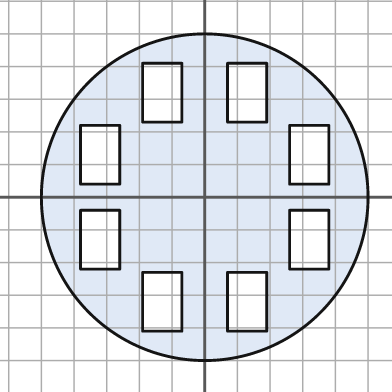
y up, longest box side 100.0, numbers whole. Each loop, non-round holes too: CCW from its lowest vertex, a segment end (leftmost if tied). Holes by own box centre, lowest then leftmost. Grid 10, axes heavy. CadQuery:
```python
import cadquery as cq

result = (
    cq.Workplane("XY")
    .moveTo(0.0, 0.0)
    .circle(50.0)
    .moveTo(-19.0, -41.0)
    .lineTo(-7.0, -41.0)
    .lineTo(-7.0, -23.0)
    .lineTo(-19.0, -23.0)
    .close()
    .moveTo(7.0, -41.0)
    .lineTo(19.0, -41.0)
    .lineTo(19.0, -23.0)
    .lineTo(7.0, -23.0)
    .close()
    .moveTo(-38.0, -22.0)
    .lineTo(-26.0, -22.0)
    .lineTo(-26.0, -4.0)
    .lineTo(-38.0, -4.0)
    .close()
    .moveTo(26.0, -22.0)
    .lineTo(38.0, -22.0)
    .lineTo(38.0, -4.0)
    .lineTo(26.0, -4.0)
    .close()
    .moveTo(-38.0, 4.0)
    .lineTo(-26.0, 4.0)
    .lineTo(-26.0, 22.0)
    .lineTo(-38.0, 22.0)
    .close()
    .moveTo(26.0, 4.0)
    .lineTo(38.0, 4.0)
    .lineTo(38.0, 22.0)
    .lineTo(26.0, 22.0)
    .close()
    .moveTo(-19.0, 23.0)
    .lineTo(-7.0, 23.0)
    .lineTo(-7.0, 41.0)
    .lineTo(-19.0, 41.0)
    .close()
    .moveTo(7.0, 23.0)
    .lineTo(19.0, 23.0)
    .lineTo(19.0, 41.0)
    .lineTo(7.0, 41.0)
    .close()
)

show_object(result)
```